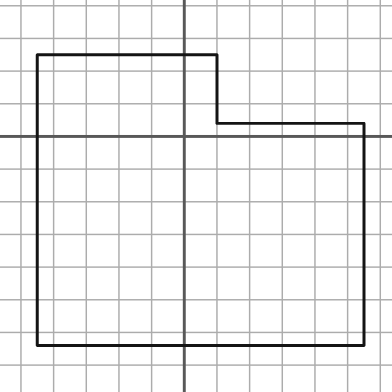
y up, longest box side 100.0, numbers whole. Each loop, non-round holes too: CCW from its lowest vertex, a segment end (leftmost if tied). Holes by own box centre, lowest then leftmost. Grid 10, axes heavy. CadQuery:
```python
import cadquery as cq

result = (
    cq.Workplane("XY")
    .moveTo(-45.0, -64.0)
    .lineTo(55.0, -64.0)
    .lineTo(55.0, 4.0)
    .lineTo(10.0, 4.0)
    .lineTo(10.0, 25.0)
    .lineTo(-45.0, 25.0)
    .close()
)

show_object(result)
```